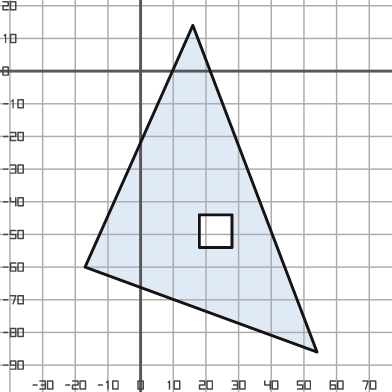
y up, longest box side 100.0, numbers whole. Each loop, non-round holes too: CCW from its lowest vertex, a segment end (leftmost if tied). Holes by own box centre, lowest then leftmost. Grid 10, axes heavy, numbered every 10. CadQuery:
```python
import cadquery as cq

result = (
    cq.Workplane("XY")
    .moveTo(54.0, -86.0)
    .lineTo(16.0, 14.0)
    .lineTo(-17.0, -60.0)
    .close()
    .moveTo(18.0, -54.0)
    .lineTo(28.0, -54.0)
    .lineTo(28.0, -44.0)
    .lineTo(18.0, -44.0)
    .close()
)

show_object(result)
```